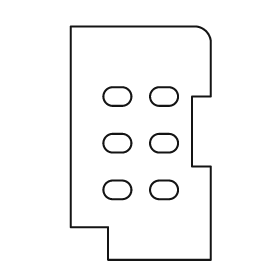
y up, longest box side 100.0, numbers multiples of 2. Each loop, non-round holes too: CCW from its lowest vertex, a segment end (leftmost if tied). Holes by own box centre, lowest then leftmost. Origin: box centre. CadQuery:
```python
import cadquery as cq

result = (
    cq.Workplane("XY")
    .moveTo(-14.0, -50.0)
    .lineTo(30.0, -50.0)
    .lineTo(30.0, -10.0)
    .lineTo(22.0, -10.0)
    .lineTo(22.0, 20.0)
    .lineTo(30.0, 20.0)
    .lineTo(30.0, 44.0)
    .threePointArc((28.0, 48.0), (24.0, 50.0))
    .lineTo(-30.0, 50.0)
    .lineTo(-30.0, -36.0)
    .lineTo(-14.0, -36.0)
    .close()
    .moveTo(-12.0, -24.0)
    .lineTo(-8.0, -24.0)
    .threePointArc((-4.0, -20.0), (-8.0, -16.0))
    .lineTo(-12.0, -16.0)
    .threePointArc((-16.0, -20.0), (-12.0, -24.0))
    .close()
    .moveTo(8.0, -24.0)
    .lineTo(12.0, -24.0)
    .threePointArc((16.0, -20.0), (12.0, -16.0))
    .lineTo(8.0, -16.0)
    .threePointArc((4.0, -20.0), (8.0, -24.0))
    .close()
    .moveTo(-12.0, -4.0)
    .lineTo(-8.0, -4.0)
    .threePointArc((-4.0, 0.0), (-8.0, 4.0))
    .lineTo(-12.0, 4.0)
    .threePointArc((-16.0, 0.0), (-12.0, -4.0))
    .close()
    .moveTo(8.0, -4.0)
    .lineTo(12.0, -4.0)
    .threePointArc((16.0, 0.0), (12.0, 4.0))
    .lineTo(8.0, 4.0)
    .threePointArc((4.0, 0.0), (8.0, -4.0))
    .close()
    .moveTo(-12.0, 16.0)
    .lineTo(-8.0, 16.0)
    .threePointArc((-4.0, 20.0), (-8.0, 24.0))
    .lineTo(-12.0, 24.0)
    .threePointArc((-16.0, 20.0), (-12.0, 16.0))
    .close()
    .moveTo(8.0, 16.0)
    .lineTo(12.0, 16.0)
    .threePointArc((16.0, 20.0), (12.0, 24.0))
    .lineTo(8.0, 24.0)
    .threePointArc((4.0, 20.0), (8.0, 16.0))
    .close()
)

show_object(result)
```